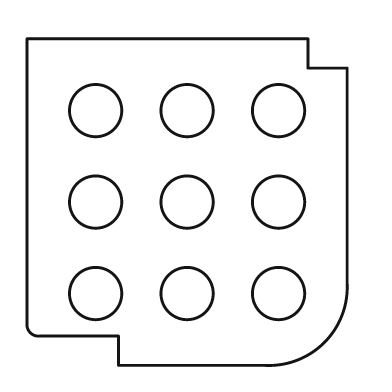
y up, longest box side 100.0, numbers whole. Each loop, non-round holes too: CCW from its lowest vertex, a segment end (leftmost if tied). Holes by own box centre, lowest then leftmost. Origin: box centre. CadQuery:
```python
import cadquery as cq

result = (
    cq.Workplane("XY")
    .moveTo(-21.0, -50.0)
    .lineTo(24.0, -50.0)
    .threePointArc((42.0, -43.0), (49.0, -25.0))
    .lineTo(49.0, 41.0)
    .lineTo(37.0, 41.0)
    .lineTo(37.0, 50.0)
    .lineTo(-49.0, 50.0)
    .lineTo(-49.0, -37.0)
    .threePointArc((-48.0, -40.0), (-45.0, -41.0))
    .lineTo(-21.0, -41.0)
    .close()
    .moveTo(-28.0, -28.0)
    .circle(8.0)
    .moveTo(0.0, -28.0)
    .circle(8.0)
    .moveTo(28.0, -28.0)
    .circle(8.0)
    .moveTo(-28.0, 0.0)
    .circle(8.0)
    .moveTo(0.0, 0.0)
    .circle(8.0)
    .moveTo(28.0, 0.0)
    .circle(8.0)
    .moveTo(-28.0, 28.0)
    .circle(8.0)
    .moveTo(0.0, 28.0)
    .circle(8.0)
    .moveTo(28.0, 28.0)
    .circle(8.0)
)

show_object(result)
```